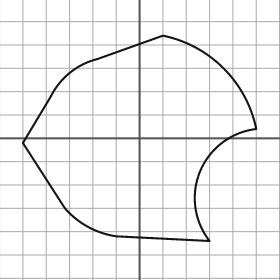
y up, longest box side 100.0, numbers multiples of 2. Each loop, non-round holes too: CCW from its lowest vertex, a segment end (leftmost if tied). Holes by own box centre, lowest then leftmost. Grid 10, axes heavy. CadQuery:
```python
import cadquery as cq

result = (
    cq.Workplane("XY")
    .moveTo(30.0, -44.0)
    .threePointArc((26.0, -14.0), (50.0, 4.0))
    .threePointArc((36.0, 30.0), (10.0, 44.0))
    .lineTo(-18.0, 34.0)
    .threePointArc((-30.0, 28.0), (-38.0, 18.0))
    .lineTo(-50.0, -2.0)
    .lineTo(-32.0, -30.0)
    .threePointArc((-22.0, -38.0), (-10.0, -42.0))
    .close()
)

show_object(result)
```